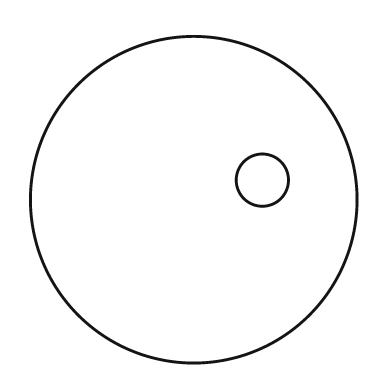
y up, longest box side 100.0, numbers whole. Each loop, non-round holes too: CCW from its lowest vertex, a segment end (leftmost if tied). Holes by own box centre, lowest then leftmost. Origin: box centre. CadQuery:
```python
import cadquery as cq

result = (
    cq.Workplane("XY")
    .moveTo(0.0, 0.0)
    .circle(50.0)
    .moveTo(21.0, 6.0)
    .circle(8.0)
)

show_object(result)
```